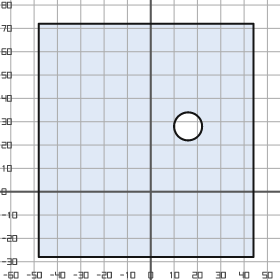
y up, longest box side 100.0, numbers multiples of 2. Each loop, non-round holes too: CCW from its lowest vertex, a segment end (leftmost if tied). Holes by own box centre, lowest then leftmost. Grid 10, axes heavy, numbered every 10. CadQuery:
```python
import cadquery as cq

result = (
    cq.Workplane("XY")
    .moveTo(-48.0, -28.0)
    .lineTo(44.0, -28.0)
    .lineTo(44.0, 72.0)
    .lineTo(-48.0, 72.0)
    .close()
    .moveTo(16.0, 28.0)
    .circle(6.0)
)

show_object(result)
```